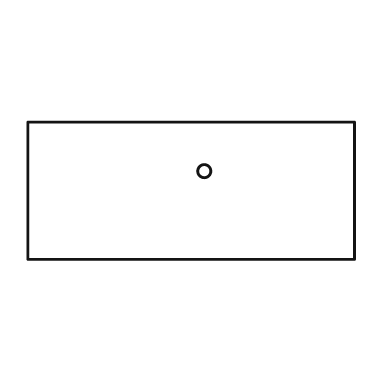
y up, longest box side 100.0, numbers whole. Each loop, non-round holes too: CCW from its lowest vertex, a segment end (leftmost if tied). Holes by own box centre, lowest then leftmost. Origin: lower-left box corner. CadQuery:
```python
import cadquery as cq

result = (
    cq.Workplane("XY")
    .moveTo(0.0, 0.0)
    .lineTo(100.0, 0.0)
    .lineTo(100.0, 42.0)
    .lineTo(0.0, 42.0)
    .close()
    .moveTo(54.0, 27.0)
    .circle(2.0)
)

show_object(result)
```